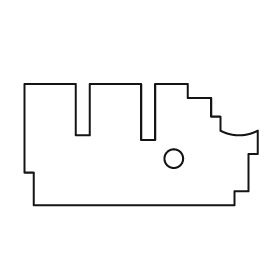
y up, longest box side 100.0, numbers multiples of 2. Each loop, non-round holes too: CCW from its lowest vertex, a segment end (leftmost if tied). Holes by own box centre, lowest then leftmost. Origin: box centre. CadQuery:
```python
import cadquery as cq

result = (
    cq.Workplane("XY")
    .moveTo(-46.0, -26.0)
    .lineTo(40.0, -26.0)
    .lineTo(40.0, -20.0)
    .lineTo(46.0, -20.0)
    .lineTo(46.0, -4.0)
    .lineTo(50.0, -4.0)
    .lineTo(50.0, 6.0)
    .threePointArc((42.0, 4.0), (34.0, 6.0))
    .lineTo(34.0, 12.0)
    .lineTo(30.0, 12.0)
    .lineTo(30.0, 20.0)
    .lineTo(20.0, 20.0)
    .lineTo(20.0, 26.0)
    .lineTo(6.0, 26.0)
    .lineTo(6.0, 2.0)
    .lineTo(0.0, 2.0)
    .lineTo(0.0, 26.0)
    .lineTo(-22.0, 26.0)
    .lineTo(-22.0, 4.0)
    .lineTo(-28.0, 4.0)
    .lineTo(-28.0, 26.0)
    .lineTo(-50.0, 26.0)
    .lineTo(-50.0, -12.0)
    .lineTo(-46.0, -12.0)
    .close()
    .moveTo(14.0, -6.0)
    .circle(4.0)
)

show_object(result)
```